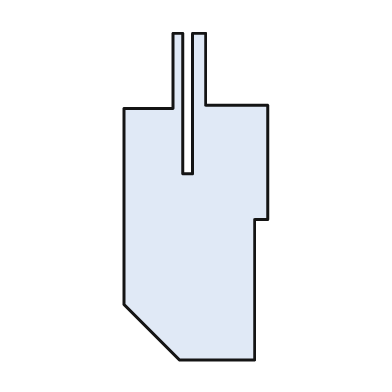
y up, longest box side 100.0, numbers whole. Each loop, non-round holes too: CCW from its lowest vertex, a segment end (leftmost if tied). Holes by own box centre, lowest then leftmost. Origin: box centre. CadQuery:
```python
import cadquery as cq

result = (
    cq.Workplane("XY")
    .moveTo(-5.0, -50.0)
    .lineTo(18.0, -50.0)
    .lineTo(18.0, -7.0)
    .lineTo(22.0, -7.0)
    .lineTo(22.0, 28.0)
    .lineTo(3.0, 28.0)
    .lineTo(3.0, 50.0)
    .lineTo(-1.0, 50.0)
    .lineTo(-1.0, 7.0)
    .lineTo(-4.0, 7.0)
    .lineTo(-4.0, 50.0)
    .lineTo(-7.0, 50.0)
    .lineTo(-7.0, 27.0)
    .lineTo(-22.0, 27.0)
    .lineTo(-22.0, -33.0)
    .close()
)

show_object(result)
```